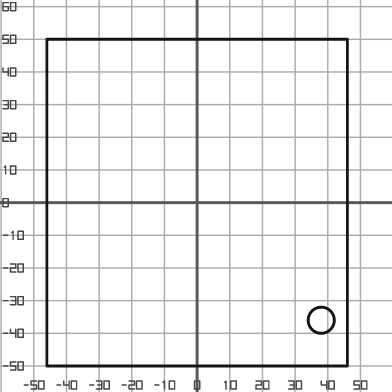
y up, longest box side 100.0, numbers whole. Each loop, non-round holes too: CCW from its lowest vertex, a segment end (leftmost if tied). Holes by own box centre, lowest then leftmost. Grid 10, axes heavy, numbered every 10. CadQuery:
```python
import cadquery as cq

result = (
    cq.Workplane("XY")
    .moveTo(-46.0, -50.0)
    .lineTo(46.0, -50.0)
    .lineTo(46.0, 50.0)
    .lineTo(-46.0, 50.0)
    .close()
    .moveTo(38.0, -36.0)
    .circle(4.0)
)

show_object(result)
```